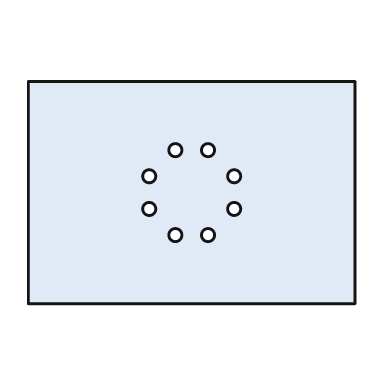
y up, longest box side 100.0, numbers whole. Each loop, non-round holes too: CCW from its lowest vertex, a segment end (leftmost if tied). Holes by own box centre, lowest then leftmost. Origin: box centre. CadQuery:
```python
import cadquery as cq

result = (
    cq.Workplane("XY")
    .moveTo(-50.0, -34.0)
    .lineTo(50.0, -34.0)
    .lineTo(50.0, 34.0)
    .lineTo(-50.0, 34.0)
    .close()
    .moveTo(-5.0, -13.0)
    .circle(2.0)
    .moveTo(5.0, -13.0)
    .circle(2.0)
    .moveTo(-13.0, -5.0)
    .circle(2.0)
    .moveTo(13.0, -5.0)
    .circle(2.0)
    .moveTo(-13.0, 5.0)
    .circle(2.0)
    .moveTo(13.0, 5.0)
    .circle(2.0)
    .moveTo(-5.0, 13.0)
    .circle(2.0)
    .moveTo(5.0, 13.0)
    .circle(2.0)
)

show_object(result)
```